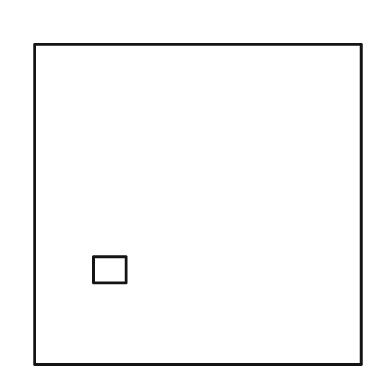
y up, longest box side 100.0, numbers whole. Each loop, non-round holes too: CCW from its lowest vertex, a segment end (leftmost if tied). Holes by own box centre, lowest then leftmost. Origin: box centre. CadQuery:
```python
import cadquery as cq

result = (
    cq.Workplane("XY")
    .moveTo(-50.0, -49.0)
    .lineTo(50.0, -49.0)
    .lineTo(50.0, 49.0)
    .lineTo(-50.0, 49.0)
    .close()
    .moveTo(-32.0, -24.0)
    .lineTo(-22.0, -24.0)
    .lineTo(-22.0, -16.0)
    .lineTo(-32.0, -16.0)
    .close()
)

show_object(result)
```